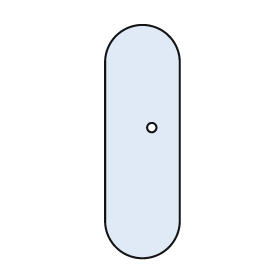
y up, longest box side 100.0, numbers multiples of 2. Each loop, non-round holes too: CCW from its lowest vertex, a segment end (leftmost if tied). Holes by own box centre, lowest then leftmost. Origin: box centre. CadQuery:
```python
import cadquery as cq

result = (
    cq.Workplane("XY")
    .moveTo(-16.0, -34.0)
    .threePointArc((0.0, -50.0), (16.0, -34.0))
    .lineTo(16.0, 34.0)
    .threePointArc((0.0, 50.0), (-16.0, 34.0))
    .close()
    .moveTo(4.0, 6.0)
    .circle(2.0)
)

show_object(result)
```